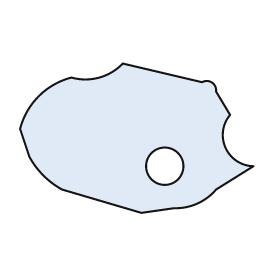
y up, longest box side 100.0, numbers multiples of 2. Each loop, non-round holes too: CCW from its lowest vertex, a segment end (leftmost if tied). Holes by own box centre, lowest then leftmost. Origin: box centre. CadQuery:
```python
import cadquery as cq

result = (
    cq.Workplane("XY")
    .moveTo(2.0, -32.0)
    .lineTo(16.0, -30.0)
    .threePointArc((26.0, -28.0), (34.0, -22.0))
    .lineTo(50.0, -12.0)
    .threePointArc((38.0, -4.0), (40.0, 10.0))
    .lineTo(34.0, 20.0)
    .threePointArc((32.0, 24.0), (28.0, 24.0))
    .lineTo(-6.0, 32.0)
    .threePointArc((-16.0, 26.0), (-28.0, 26.0))
    .threePointArc((-42.0, 18.0), (-50.0, 4.0))
    .lineTo(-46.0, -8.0)
    .threePointArc((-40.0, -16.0), (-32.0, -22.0))
    .close()
    .moveTo(12.0, -12.0)
    .circle(8.0)
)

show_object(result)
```